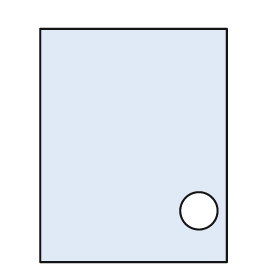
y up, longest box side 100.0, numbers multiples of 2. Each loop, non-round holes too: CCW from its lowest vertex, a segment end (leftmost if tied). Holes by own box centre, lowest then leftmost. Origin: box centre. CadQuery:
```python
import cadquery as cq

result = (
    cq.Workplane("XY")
    .moveTo(-40.0, -50.0)
    .lineTo(40.0, -50.0)
    .lineTo(40.0, 50.0)
    .lineTo(-40.0, 50.0)
    .close()
    .moveTo(28.0, -28.0)
    .circle(8.0)
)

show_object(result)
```